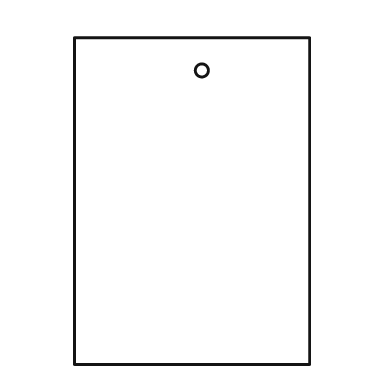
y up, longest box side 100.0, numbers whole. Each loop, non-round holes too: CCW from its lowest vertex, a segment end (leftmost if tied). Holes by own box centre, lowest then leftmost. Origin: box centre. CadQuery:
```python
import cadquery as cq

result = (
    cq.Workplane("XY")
    .moveTo(-36.0, -50.0)
    .lineTo(36.0, -50.0)
    .lineTo(36.0, 50.0)
    .lineTo(-36.0, 50.0)
    .close()
    .moveTo(3.0, 40.0)
    .circle(2.0)
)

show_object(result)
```